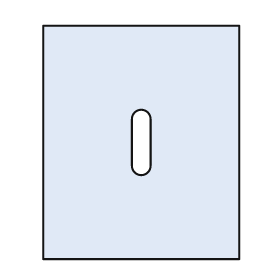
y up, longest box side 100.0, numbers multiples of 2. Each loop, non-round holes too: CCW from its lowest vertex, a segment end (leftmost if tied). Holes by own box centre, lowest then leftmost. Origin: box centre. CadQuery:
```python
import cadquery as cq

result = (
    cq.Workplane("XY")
    .moveTo(-42.0, -50.0)
    .lineTo(42.0, -50.0)
    .lineTo(42.0, 50.0)
    .lineTo(-42.0, 50.0)
    .close()
    .moveTo(-4.0, -10.0)
    .threePointArc((0.0, -14.0), (4.0, -10.0))
    .lineTo(4.0, 10.0)
    .threePointArc((0.0, 14.0), (-4.0, 10.0))
    .close()
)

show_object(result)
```